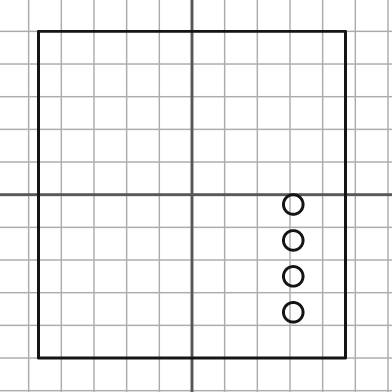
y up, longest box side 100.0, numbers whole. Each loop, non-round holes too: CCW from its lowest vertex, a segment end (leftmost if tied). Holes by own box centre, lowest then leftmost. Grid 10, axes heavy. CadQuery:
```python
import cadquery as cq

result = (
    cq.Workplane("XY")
    .moveTo(-47.0, -50.0)
    .lineTo(47.0, -50.0)
    .lineTo(47.0, 50.0)
    .lineTo(-47.0, 50.0)
    .close()
    .moveTo(31.0, -36.0)
    .circle(3.0)
    .moveTo(31.0, -25.0)
    .circle(3.0)
    .moveTo(31.0, -14.0)
    .circle(3.0)
    .moveTo(31.0, -3.0)
    .circle(3.0)
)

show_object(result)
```